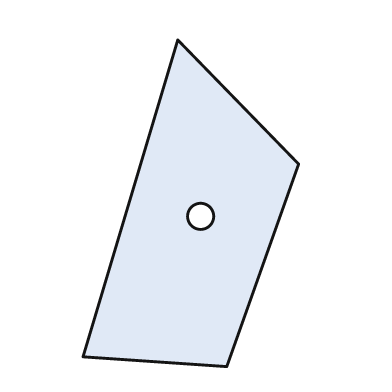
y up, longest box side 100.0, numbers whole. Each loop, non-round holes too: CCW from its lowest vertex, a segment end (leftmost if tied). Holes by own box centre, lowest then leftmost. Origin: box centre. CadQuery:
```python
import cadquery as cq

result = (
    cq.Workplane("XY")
    .moveTo(11.0, -50.0)
    .lineTo(33.0, 12.0)
    .lineTo(-4.0, 50.0)
    .lineTo(-33.0, -47.0)
    .close()
    .moveTo(3.0, -4.0)
    .circle(4.0)
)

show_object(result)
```